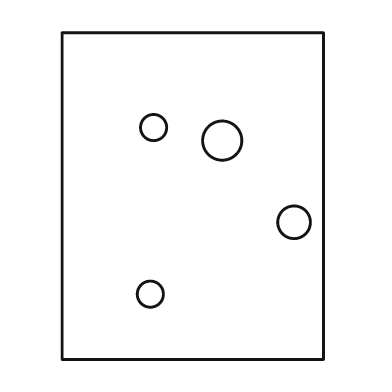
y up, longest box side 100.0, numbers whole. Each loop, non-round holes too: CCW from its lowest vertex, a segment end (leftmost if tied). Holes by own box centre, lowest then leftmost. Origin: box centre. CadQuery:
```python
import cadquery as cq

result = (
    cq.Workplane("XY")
    .moveTo(-40.0, -50.0)
    .lineTo(40.0, -50.0)
    .lineTo(40.0, 50.0)
    .lineTo(-40.0, 50.0)
    .close()
    .moveTo(-13.0, -30.0)
    .circle(4.0)
    .moveTo(31.0, -8.0)
    .circle(5.0)
    .moveTo(9.0, 17.0)
    .circle(6.0)
    .moveTo(-12.0, 21.0)
    .circle(4.0)
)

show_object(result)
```